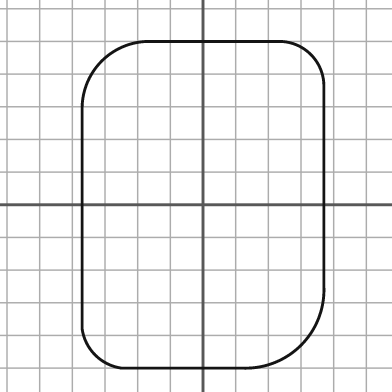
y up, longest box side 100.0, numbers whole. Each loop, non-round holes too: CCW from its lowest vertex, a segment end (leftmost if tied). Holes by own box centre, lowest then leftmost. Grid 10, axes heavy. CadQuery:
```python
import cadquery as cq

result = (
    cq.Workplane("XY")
    .moveTo(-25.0, -50.0)
    .lineTo(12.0, -50.0)
    .threePointArc((30.0, -43.0), (37.0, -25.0))
    .lineTo(37.0, 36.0)
    .threePointArc((33.0, 46.0), (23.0, 50.0))
    .lineTo(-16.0, 50.0)
    .threePointArc((-31.0, 44.0), (-37.0, 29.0))
    .lineTo(-37.0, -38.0)
    .threePointArc((-33.0, -46.0), (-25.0, -50.0))
    .close()
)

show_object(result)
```